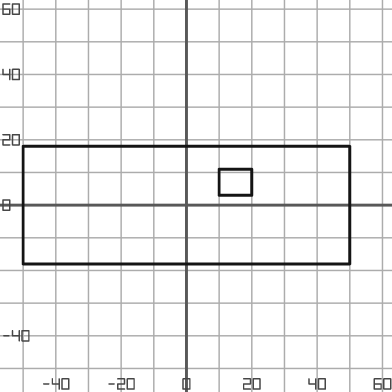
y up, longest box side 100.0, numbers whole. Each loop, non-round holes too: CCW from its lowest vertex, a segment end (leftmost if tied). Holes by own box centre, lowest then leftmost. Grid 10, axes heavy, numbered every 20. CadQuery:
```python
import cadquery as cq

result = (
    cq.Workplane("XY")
    .moveTo(-50.0, -18.0)
    .lineTo(50.0, -18.0)
    .lineTo(50.0, 18.0)
    .lineTo(-50.0, 18.0)
    .close()
    .moveTo(10.0, 3.0)
    .lineTo(20.0, 3.0)
    .lineTo(20.0, 11.0)
    .lineTo(10.0, 11.0)
    .close()
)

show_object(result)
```